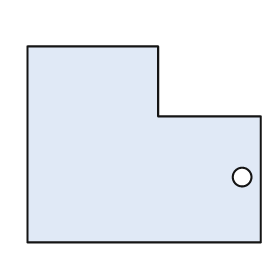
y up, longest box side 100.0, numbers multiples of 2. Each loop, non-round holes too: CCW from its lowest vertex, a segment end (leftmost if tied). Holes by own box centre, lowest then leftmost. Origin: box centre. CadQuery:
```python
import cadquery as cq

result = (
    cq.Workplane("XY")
    .moveTo(-50.0, -42.0)
    .lineTo(50.0, -42.0)
    .lineTo(50.0, 12.0)
    .lineTo(6.0, 12.0)
    .lineTo(6.0, 42.0)
    .lineTo(-50.0, 42.0)
    .close()
    .moveTo(42.0, -14.0)
    .circle(4.0)
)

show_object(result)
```